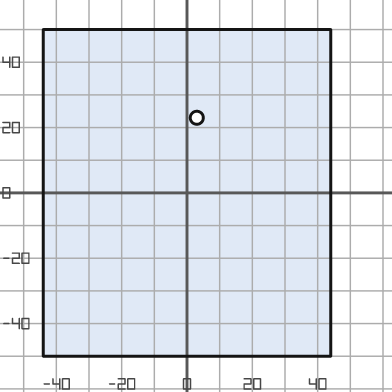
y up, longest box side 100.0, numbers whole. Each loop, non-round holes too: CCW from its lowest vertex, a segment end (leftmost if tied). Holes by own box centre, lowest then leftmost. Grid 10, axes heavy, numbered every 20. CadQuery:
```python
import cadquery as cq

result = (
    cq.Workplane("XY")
    .moveTo(-44.0, -50.0)
    .lineTo(44.0, -50.0)
    .lineTo(44.0, 50.0)
    .lineTo(-44.0, 50.0)
    .close()
    .moveTo(3.0, 23.0)
    .circle(2.0)
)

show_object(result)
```